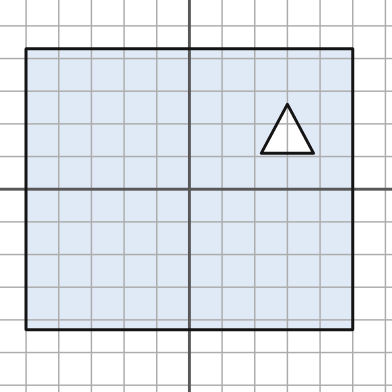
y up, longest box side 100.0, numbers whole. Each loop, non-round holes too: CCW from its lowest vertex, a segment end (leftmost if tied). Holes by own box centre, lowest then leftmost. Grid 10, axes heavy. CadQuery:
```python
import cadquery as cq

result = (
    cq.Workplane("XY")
    .moveTo(-50.0, -43.0)
    .lineTo(50.0, -43.0)
    .lineTo(50.0, 43.0)
    .lineTo(-50.0, 43.0)
    .close()
    .moveTo(22.0, 11.0)
    .lineTo(38.0, 11.0)
    .lineTo(30.0, 26.0)
    .close()
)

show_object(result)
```